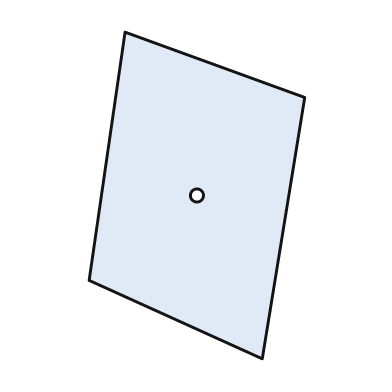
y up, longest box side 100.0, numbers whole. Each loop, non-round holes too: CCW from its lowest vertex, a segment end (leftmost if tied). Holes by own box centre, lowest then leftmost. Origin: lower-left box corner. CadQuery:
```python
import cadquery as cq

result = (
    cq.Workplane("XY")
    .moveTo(53.0, 0.0)
    .lineTo(66.0, 80.0)
    .lineTo(11.0, 100.0)
    .lineTo(0.0, 24.0)
    .close()
    .moveTo(33.0, 50.0)
    .circle(2.0)
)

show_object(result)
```